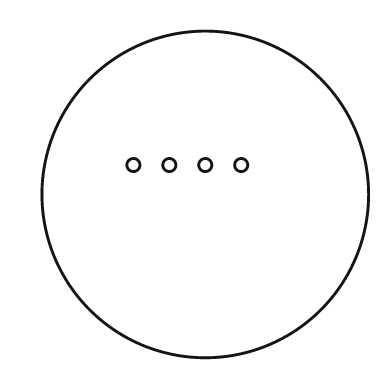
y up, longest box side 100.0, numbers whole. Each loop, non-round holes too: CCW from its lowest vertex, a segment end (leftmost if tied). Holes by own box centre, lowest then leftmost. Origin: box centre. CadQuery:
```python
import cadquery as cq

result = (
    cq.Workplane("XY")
    .moveTo(0.0, 0.0)
    .circle(50.0)
    .moveTo(-22.0, 9.0)
    .circle(2.0)
    .moveTo(-11.0, 9.0)
    .circle(2.0)
    .moveTo(0.0, 9.0)
    .circle(2.0)
    .moveTo(11.0, 9.0)
    .circle(2.0)
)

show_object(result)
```